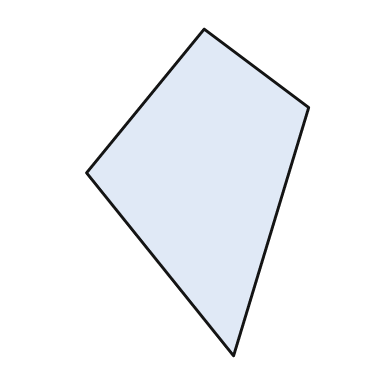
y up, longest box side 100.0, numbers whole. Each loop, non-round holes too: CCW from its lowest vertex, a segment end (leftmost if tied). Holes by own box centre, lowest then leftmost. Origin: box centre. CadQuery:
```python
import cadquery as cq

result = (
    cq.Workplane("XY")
    .moveTo(11.0, -50.0)
    .lineTo(34.0, 26.0)
    .lineTo(2.0, 50.0)
    .lineTo(-34.0, 6.0)
    .close()
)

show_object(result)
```